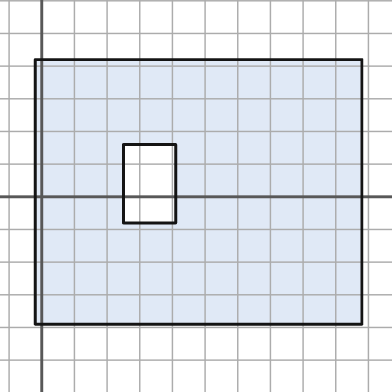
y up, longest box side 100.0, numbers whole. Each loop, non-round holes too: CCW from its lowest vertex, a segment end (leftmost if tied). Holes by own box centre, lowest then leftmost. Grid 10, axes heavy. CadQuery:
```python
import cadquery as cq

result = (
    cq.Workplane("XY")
    .moveTo(-2.0, -39.0)
    .lineTo(98.0, -39.0)
    .lineTo(98.0, 42.0)
    .lineTo(-2.0, 42.0)
    .close()
    .moveTo(25.0, -8.0)
    .lineTo(41.0, -8.0)
    .lineTo(41.0, 16.0)
    .lineTo(25.0, 16.0)
    .close()
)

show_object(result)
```